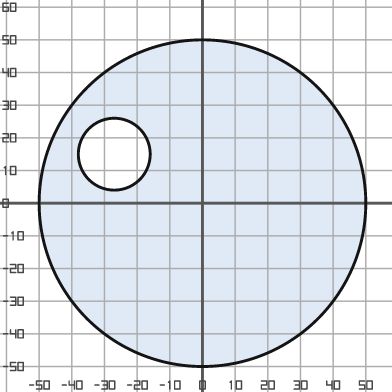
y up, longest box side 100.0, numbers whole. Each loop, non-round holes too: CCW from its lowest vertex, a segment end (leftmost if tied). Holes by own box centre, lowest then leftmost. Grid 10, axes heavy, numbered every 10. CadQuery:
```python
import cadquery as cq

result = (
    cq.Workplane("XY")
    .moveTo(0.0, 0.0)
    .circle(50.0)
    .moveTo(-27.0, 15.0)
    .circle(11.0)
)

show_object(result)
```